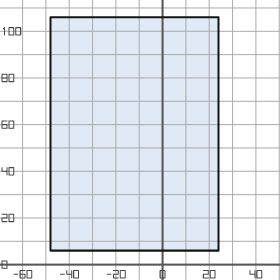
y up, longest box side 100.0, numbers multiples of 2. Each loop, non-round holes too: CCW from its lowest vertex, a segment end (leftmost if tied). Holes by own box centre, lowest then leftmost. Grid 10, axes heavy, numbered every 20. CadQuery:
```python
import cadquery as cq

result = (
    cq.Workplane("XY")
    .moveTo(-48.0, 6.0)
    .lineTo(24.0, 6.0)
    .lineTo(24.0, 106.0)
    .lineTo(-48.0, 106.0)
    .close()
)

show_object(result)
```